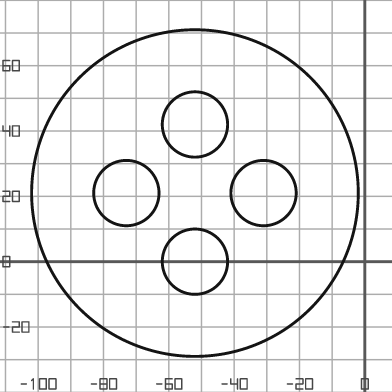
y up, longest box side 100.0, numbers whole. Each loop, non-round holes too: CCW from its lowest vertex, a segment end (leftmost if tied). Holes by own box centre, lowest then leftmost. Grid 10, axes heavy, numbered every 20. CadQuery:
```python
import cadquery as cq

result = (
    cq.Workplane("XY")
    .moveTo(-52.0, 21.0)
    .circle(50.0)
    .moveTo(-52.0, 0.0)
    .circle(10.0)
    .moveTo(-73.0, 21.0)
    .circle(10.0)
    .moveTo(-31.0, 21.0)
    .circle(10.0)
    .moveTo(-52.0, 42.0)
    .circle(10.0)
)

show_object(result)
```